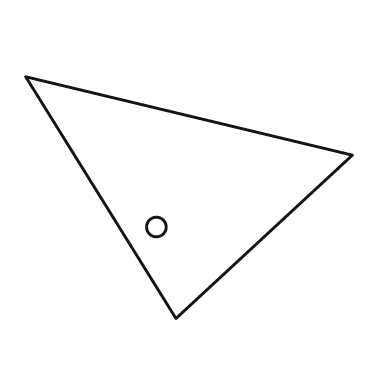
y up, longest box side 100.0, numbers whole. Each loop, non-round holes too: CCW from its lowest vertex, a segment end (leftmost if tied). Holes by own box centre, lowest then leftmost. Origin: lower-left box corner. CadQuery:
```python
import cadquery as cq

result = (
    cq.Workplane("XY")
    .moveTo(46.0, 0.0)
    .lineTo(100.0, 50.0)
    .lineTo(0.0, 74.0)
    .close()
    .moveTo(40.0, 28.0)
    .circle(3.0)
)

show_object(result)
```